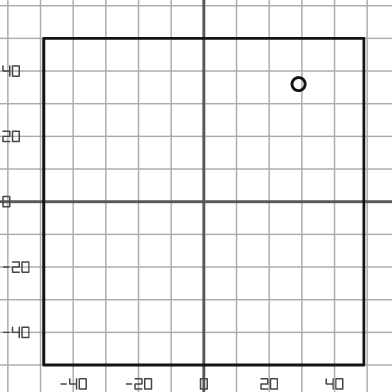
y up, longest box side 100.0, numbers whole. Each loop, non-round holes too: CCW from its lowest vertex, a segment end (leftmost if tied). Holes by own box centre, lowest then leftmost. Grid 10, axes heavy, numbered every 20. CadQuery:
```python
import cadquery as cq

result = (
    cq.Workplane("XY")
    .moveTo(-49.0, -50.0)
    .lineTo(49.0, -50.0)
    .lineTo(49.0, 50.0)
    .lineTo(-49.0, 50.0)
    .close()
    .moveTo(29.0, 36.0)
    .circle(2.0)
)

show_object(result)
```